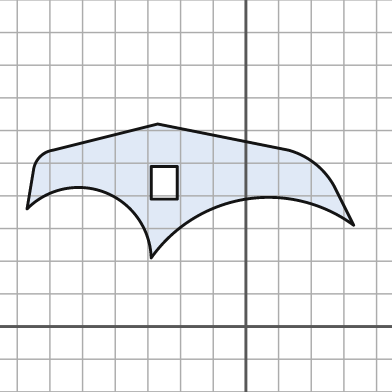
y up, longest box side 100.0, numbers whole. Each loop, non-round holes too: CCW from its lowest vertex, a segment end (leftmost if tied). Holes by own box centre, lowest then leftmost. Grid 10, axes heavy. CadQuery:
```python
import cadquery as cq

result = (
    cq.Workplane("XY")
    .moveTo(-29.0, 21.0)
    .threePointArc((0.0, 39.0), (33.0, 31.0))
    .lineTo(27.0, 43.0)
    .threePointArc((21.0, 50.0), (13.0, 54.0))
    .lineTo(-27.0, 62.0)
    .lineTo(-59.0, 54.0)
    .threePointArc((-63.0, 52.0), (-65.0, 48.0))
    .lineTo(-67.0, 36.0)
    .threePointArc((-43.0, 41.0), (-29.0, 21.0))
    .close()
    .moveTo(-29.0, 39.0)
    .lineTo(-21.0, 39.0)
    .lineTo(-21.0, 49.0)
    .lineTo(-29.0, 49.0)
    .close()
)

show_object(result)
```